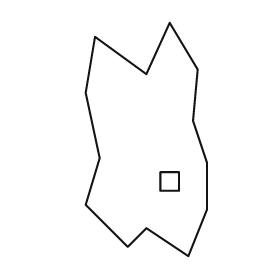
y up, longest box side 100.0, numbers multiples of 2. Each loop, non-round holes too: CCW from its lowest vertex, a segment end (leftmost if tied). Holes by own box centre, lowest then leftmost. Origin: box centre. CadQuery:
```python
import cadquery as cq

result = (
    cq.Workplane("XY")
    .moveTo(18.0, -50.0)
    .lineTo(26.0, -30.0)
    .lineTo(26.0, -10.0)
    .lineTo(20.0, 8.0)
    .lineTo(22.0, 30.0)
    .lineTo(10.0, 50.0)
    .lineTo(0.0, 28.0)
    .lineTo(-22.0, 44.0)
    .lineTo(-26.0, 20.0)
    .lineTo(-20.0, -8.0)
    .lineTo(-26.0, -28.0)
    .lineTo(-8.0, -46.0)
    .lineTo(0.0, -38.0)
    .close()
    .moveTo(6.0, -22.0)
    .lineTo(14.0, -22.0)
    .lineTo(14.0, -14.0)
    .lineTo(6.0, -14.0)
    .close()
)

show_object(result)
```